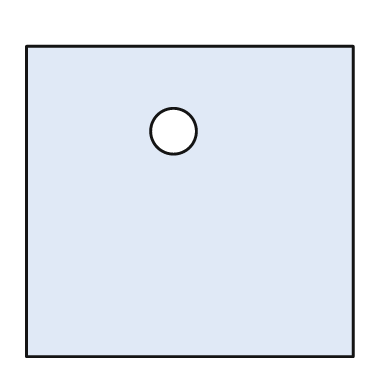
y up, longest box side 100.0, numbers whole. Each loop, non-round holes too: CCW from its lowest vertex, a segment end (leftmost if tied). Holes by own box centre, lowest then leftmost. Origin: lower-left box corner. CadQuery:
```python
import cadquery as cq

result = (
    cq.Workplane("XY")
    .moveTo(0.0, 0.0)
    .lineTo(100.0, 0.0)
    .lineTo(100.0, 95.0)
    .lineTo(0.0, 95.0)
    .close()
    .moveTo(45.0, 69.0)
    .circle(7.0)
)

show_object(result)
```